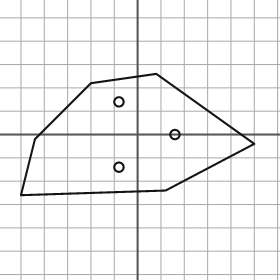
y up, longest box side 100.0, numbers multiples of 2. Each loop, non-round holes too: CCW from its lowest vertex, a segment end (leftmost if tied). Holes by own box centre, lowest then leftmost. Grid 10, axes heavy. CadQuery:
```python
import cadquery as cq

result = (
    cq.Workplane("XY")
    .moveTo(-50.0, -26.0)
    .lineTo(12.0, -24.0)
    .lineTo(50.0, -4.0)
    .lineTo(8.0, 26.0)
    .lineTo(-20.0, 22.0)
    .lineTo(-44.0, -2.0)
    .close()
    .moveTo(-8.0, -14.0)
    .circle(2.0)
    .moveTo(16.0, 0.0)
    .circle(2.0)
    .moveTo(-8.0, 14.0)
    .circle(2.0)
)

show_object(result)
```